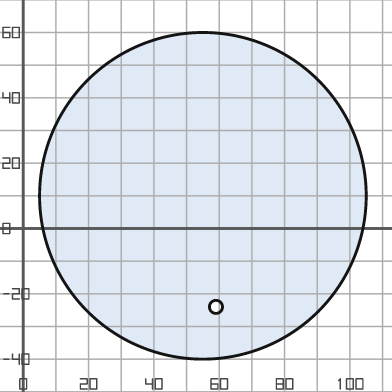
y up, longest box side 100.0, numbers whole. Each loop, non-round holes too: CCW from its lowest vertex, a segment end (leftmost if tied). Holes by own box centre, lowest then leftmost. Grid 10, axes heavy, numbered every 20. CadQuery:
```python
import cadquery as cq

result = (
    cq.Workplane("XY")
    .moveTo(55.0, 10.0)
    .circle(50.0)
    .moveTo(59.0, -24.0)
    .circle(2.0)
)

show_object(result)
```